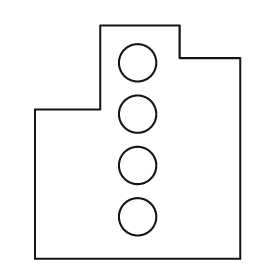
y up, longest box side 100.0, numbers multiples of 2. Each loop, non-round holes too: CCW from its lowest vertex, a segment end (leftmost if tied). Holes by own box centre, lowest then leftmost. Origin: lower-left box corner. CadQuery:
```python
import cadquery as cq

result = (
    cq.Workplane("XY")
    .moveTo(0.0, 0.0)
    .lineTo(88.0, 0.0)
    .lineTo(88.0, 86.0)
    .lineTo(62.0, 86.0)
    .lineTo(62.0, 100.0)
    .lineTo(28.0, 100.0)
    .lineTo(28.0, 64.0)
    .lineTo(0.0, 64.0)
    .close()
    .moveTo(44.0, 18.0)
    .circle(8.0)
    .moveTo(44.0, 40.0)
    .circle(8.0)
    .moveTo(44.0, 62.0)
    .circle(8.0)
    .moveTo(44.0, 84.0)
    .circle(8.0)
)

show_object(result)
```